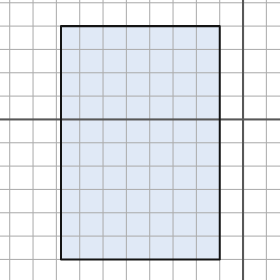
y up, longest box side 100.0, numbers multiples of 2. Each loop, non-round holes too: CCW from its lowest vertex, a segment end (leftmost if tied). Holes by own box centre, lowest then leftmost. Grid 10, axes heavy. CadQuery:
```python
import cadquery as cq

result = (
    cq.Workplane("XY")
    .moveTo(-78.0, -60.0)
    .lineTo(-10.0, -60.0)
    .lineTo(-10.0, 40.0)
    .lineTo(-78.0, 40.0)
    .close()
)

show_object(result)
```